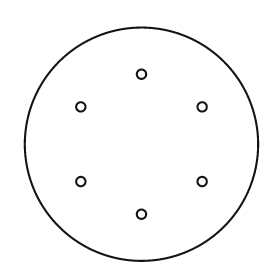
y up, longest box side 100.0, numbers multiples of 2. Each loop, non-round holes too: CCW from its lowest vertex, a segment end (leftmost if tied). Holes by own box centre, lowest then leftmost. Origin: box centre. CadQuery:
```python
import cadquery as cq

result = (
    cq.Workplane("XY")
    .moveTo(0.0, 0.0)
    .circle(50.0)
    .moveTo(0.0, -30.0)
    .circle(2.0)
    .moveTo(-26.0, -16.0)
    .circle(2.0)
    .moveTo(26.0, -16.0)
    .circle(2.0)
    .moveTo(-26.0, 16.0)
    .circle(2.0)
    .moveTo(26.0, 16.0)
    .circle(2.0)
    .moveTo(0.0, 30.0)
    .circle(2.0)
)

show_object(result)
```